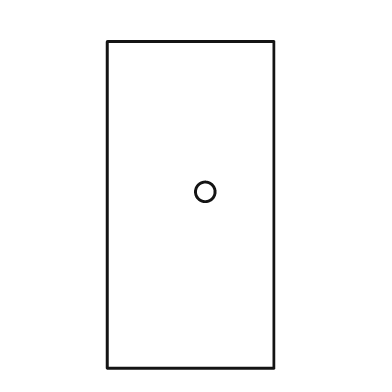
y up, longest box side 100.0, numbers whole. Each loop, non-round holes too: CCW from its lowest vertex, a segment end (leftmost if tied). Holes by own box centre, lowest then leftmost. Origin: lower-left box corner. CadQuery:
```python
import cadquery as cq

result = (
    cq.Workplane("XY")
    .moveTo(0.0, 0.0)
    .lineTo(51.0, 0.0)
    .lineTo(51.0, 100.0)
    .lineTo(0.0, 100.0)
    .close()
    .moveTo(30.0, 54.0)
    .circle(3.0)
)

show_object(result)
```